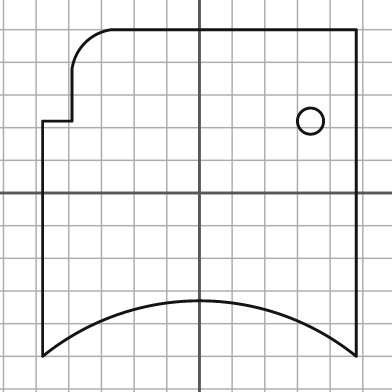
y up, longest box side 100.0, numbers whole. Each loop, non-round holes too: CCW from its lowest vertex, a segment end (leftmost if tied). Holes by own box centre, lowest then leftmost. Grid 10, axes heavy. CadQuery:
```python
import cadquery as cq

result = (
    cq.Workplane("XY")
    .moveTo(-48.0, -50.0)
    .threePointArc((0.0, -33.0), (48.0, -50.0))
    .lineTo(48.0, 50.0)
    .lineTo(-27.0, 50.0)
    .threePointArc((-35.0, 46.0), (-39.0, 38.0))
    .lineTo(-39.0, 22.0)
    .lineTo(-48.0, 22.0)
    .close()
    .moveTo(34.0, 22.0)
    .circle(4.0)
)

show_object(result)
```